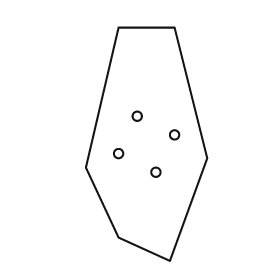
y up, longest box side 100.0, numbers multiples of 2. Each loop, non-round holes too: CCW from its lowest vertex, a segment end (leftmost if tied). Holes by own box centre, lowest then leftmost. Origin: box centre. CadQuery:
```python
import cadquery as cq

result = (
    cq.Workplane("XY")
    .moveTo(10.0, -50.0)
    .lineTo(26.0, -6.0)
    .lineTo(12.0, 50.0)
    .lineTo(-12.0, 50.0)
    .lineTo(-26.0, -10.0)
    .lineTo(-12.0, -40.0)
    .close()
    .moveTo(4.0, -12.0)
    .circle(2.0)
    .moveTo(-12.0, -4.0)
    .circle(2.0)
    .moveTo(12.0, 4.0)
    .circle(2.0)
    .moveTo(-4.0, 12.0)
    .circle(2.0)
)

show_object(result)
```